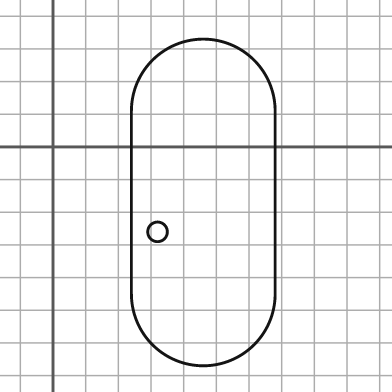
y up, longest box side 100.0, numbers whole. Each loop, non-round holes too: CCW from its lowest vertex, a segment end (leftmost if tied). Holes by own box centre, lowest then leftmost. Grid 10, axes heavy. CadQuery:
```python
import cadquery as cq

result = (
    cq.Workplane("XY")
    .moveTo(24.0, -45.0)
    .threePointArc((46.0, -67.0), (68.0, -45.0))
    .lineTo(68.0, 11.0)
    .threePointArc((46.0, 33.0), (24.0, 11.0))
    .close()
    .moveTo(32.0, -26.0)
    .circle(3.0)
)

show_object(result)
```